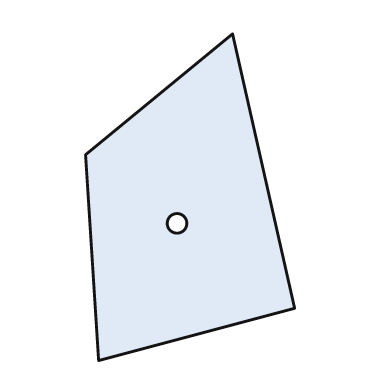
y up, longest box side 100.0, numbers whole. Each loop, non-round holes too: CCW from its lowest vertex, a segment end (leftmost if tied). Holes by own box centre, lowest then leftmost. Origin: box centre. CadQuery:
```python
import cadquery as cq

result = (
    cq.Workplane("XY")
    .moveTo(-28.0, -50.0)
    .lineTo(32.0, -34.0)
    .lineTo(13.0, 50.0)
    .lineTo(-32.0, 13.0)
    .close()
    .moveTo(-4.0, -8.0)
    .circle(3.0)
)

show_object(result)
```